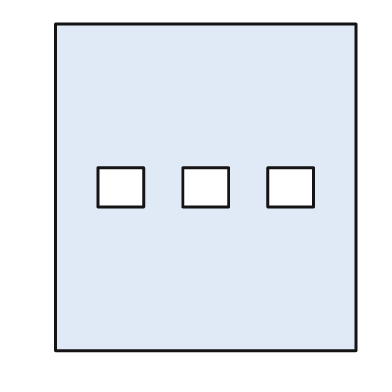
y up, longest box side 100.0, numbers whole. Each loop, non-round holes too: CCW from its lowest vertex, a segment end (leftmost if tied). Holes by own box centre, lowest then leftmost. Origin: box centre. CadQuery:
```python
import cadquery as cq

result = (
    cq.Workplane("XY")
    .moveTo(-46.0, -50.0)
    .lineTo(46.0, -50.0)
    .lineTo(46.0, 50.0)
    .lineTo(-46.0, 50.0)
    .close()
    .moveTo(-33.0, -6.0)
    .lineTo(-19.0, -6.0)
    .lineTo(-19.0, 6.0)
    .lineTo(-33.0, 6.0)
    .close()
    .moveTo(-7.0, -6.0)
    .lineTo(7.0, -6.0)
    .lineTo(7.0, 6.0)
    .lineTo(-7.0, 6.0)
    .close()
    .moveTo(19.0, -6.0)
    .lineTo(33.0, -6.0)
    .lineTo(33.0, 6.0)
    .lineTo(19.0, 6.0)
    .close()
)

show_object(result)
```